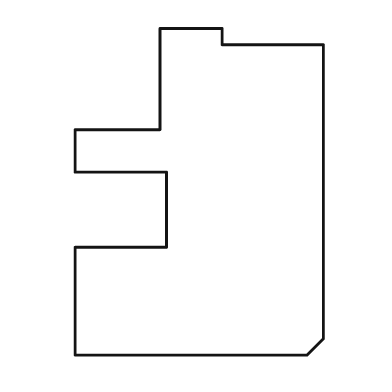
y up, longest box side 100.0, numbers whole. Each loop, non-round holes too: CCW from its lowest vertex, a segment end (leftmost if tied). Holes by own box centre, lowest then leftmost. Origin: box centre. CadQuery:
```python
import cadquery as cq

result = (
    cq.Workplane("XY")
    .moveTo(-38.0, -50.0)
    .lineTo(33.0, -50.0)
    .lineTo(38.0, -45.0)
    .lineTo(38.0, 45.0)
    .lineTo(7.0, 45.0)
    .lineTo(7.0, 50.0)
    .lineTo(-12.0, 50.0)
    .lineTo(-12.0, 19.0)
    .lineTo(-38.0, 19.0)
    .lineTo(-38.0, 6.0)
    .lineTo(-10.0, 6.0)
    .lineTo(-10.0, -17.0)
    .lineTo(-38.0, -17.0)
    .close()
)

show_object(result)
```